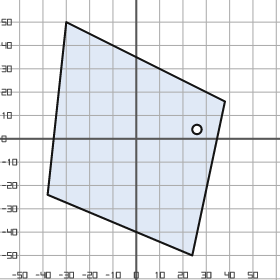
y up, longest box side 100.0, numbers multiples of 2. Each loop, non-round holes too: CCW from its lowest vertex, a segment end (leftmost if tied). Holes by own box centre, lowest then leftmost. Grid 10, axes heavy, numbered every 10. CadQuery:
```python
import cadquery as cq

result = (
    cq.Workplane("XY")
    .moveTo(24.0, -50.0)
    .lineTo(38.0, 16.0)
    .lineTo(-30.0, 50.0)
    .lineTo(-38.0, -24.0)
    .close()
    .moveTo(26.0, 4.0)
    .circle(2.0)
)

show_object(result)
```